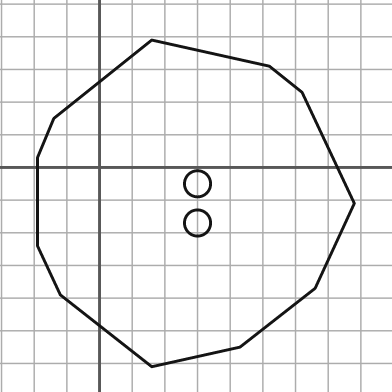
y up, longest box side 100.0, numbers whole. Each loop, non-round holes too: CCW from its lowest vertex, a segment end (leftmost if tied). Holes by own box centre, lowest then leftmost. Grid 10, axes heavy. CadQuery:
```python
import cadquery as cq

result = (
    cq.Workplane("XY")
    .moveTo(16.0, -61.0)
    .lineTo(43.0, -55.0)
    .lineTo(66.0, -37.0)
    .lineTo(78.0, -11.0)
    .lineTo(62.0, 23.0)
    .lineTo(52.0, 31.0)
    .lineTo(16.0, 39.0)
    .lineTo(-14.0, 15.0)
    .lineTo(-19.0, 3.0)
    .lineTo(-19.0, -24.0)
    .lineTo(-12.0, -39.0)
    .close()
    .moveTo(30.0, -17.0)
    .circle(4.0)
    .moveTo(30.0, -5.0)
    .circle(4.0)
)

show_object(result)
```